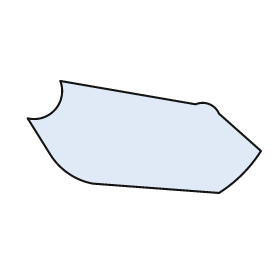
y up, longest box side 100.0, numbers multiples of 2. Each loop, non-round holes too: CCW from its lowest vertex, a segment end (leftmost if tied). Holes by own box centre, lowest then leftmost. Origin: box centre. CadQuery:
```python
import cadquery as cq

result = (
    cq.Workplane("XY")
    .moveTo(32.0, -24.0)
    .threePointArc((42.0, -16.0), (50.0, -6.0))
    .lineTo(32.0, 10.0)
    .threePointArc((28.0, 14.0), (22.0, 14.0))
    .lineTo(-36.0, 24.0)
    .threePointArc((-38.0, 12.0), (-50.0, 8.0))
    .lineTo(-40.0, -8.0)
    .threePointArc((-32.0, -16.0), (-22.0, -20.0))
    .close()
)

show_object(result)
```